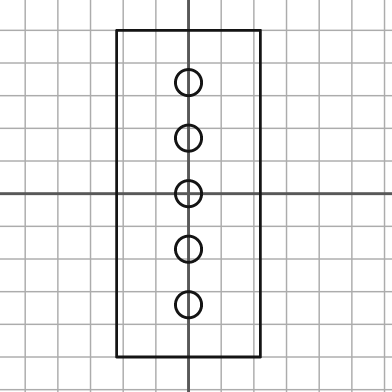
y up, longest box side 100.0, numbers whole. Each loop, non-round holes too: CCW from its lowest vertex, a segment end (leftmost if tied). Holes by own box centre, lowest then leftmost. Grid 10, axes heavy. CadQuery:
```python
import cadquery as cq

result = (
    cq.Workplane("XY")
    .moveTo(-22.0, -50.0)
    .lineTo(22.0, -50.0)
    .lineTo(22.0, 50.0)
    .lineTo(-22.0, 50.0)
    .close()
    .moveTo(0.0, -34.0)
    .circle(4.0)
    .moveTo(0.0, -17.0)
    .circle(4.0)
    .moveTo(0.0, 0.0)
    .circle(4.0)
    .moveTo(0.0, 17.0)
    .circle(4.0)
    .moveTo(0.0, 34.0)
    .circle(4.0)
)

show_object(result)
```